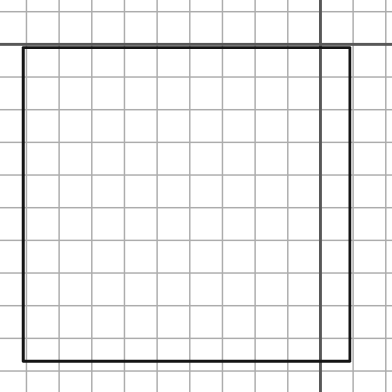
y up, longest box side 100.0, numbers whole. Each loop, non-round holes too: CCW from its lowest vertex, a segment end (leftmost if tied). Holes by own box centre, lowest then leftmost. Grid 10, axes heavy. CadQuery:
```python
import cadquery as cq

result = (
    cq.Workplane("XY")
    .moveTo(-91.0, -97.0)
    .lineTo(9.0, -97.0)
    .lineTo(9.0, -1.0)
    .lineTo(-91.0, -1.0)
    .close()
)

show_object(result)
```